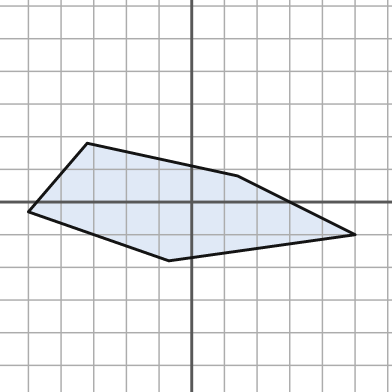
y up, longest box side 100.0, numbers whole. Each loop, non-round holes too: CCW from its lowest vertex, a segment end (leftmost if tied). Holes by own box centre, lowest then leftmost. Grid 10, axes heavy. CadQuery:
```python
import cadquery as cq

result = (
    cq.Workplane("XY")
    .moveTo(-7.0, -18.0)
    .lineTo(50.0, -10.0)
    .lineTo(14.0, 8.0)
    .lineTo(-32.0, 18.0)
    .lineTo(-50.0, -3.0)
    .close()
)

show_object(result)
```